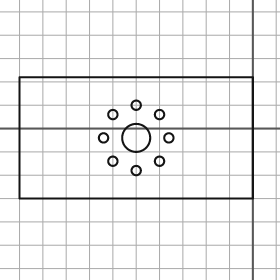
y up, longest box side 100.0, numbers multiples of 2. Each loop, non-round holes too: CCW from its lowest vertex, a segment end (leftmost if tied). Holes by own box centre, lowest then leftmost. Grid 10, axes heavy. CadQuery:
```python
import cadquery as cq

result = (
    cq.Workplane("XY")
    .moveTo(-100.0, -30.0)
    .lineTo(0.0, -30.0)
    .lineTo(0.0, 22.0)
    .lineTo(-100.0, 22.0)
    .close()
    .moveTo(-50.0, -18.0)
    .circle(2.0)
    .moveTo(-60.0, -14.0)
    .circle(2.0)
    .moveTo(-40.0, -14.0)
    .circle(2.0)
    .moveTo(-64.0, -4.0)
    .circle(2.0)
    .moveTo(-50.0, -4.0)
    .circle(6.0)
    .moveTo(-36.0, -4.0)
    .circle(2.0)
    .moveTo(-60.0, 6.0)
    .circle(2.0)
    .moveTo(-40.0, 6.0)
    .circle(2.0)
    .moveTo(-50.0, 10.0)
    .circle(2.0)
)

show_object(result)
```